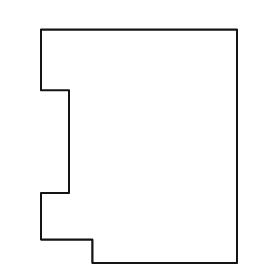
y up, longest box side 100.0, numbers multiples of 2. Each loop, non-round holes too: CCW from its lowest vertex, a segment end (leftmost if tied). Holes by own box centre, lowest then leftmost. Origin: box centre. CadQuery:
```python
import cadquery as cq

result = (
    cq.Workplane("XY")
    .moveTo(-20.0, -50.0)
    .lineTo(42.0, -50.0)
    .lineTo(42.0, 50.0)
    .lineTo(-42.0, 50.0)
    .lineTo(-42.0, 24.0)
    .lineTo(-30.0, 24.0)
    .lineTo(-30.0, -20.0)
    .lineTo(-42.0, -20.0)
    .lineTo(-42.0, -40.0)
    .lineTo(-20.0, -40.0)
    .close()
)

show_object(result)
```